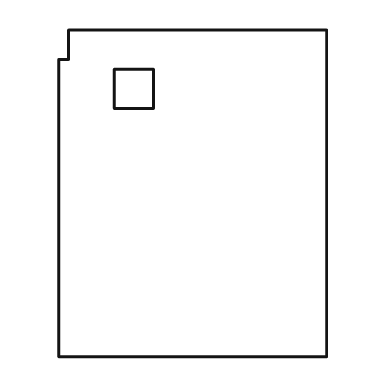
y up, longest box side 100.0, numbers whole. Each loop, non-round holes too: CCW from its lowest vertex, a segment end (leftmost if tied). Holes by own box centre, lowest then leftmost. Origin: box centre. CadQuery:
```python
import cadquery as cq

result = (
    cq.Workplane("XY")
    .moveTo(-41.0, -50.0)
    .lineTo(41.0, -50.0)
    .lineTo(41.0, 50.0)
    .lineTo(-38.0, 50.0)
    .lineTo(-38.0, 41.0)
    .lineTo(-41.0, 41.0)
    .close()
    .moveTo(-24.0, 26.0)
    .lineTo(-12.0, 26.0)
    .lineTo(-12.0, 38.0)
    .lineTo(-24.0, 38.0)
    .close()
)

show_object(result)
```